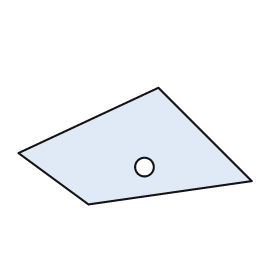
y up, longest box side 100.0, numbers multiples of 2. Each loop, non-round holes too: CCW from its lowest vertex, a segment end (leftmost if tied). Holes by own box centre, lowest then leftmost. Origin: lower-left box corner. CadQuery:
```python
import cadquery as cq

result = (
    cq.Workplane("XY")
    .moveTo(30.0, 0.0)
    .lineTo(100.0, 10.0)
    .lineTo(60.0, 50.0)
    .lineTo(0.0, 22.0)
    .close()
    .moveTo(54.0, 16.0)
    .circle(4.0)
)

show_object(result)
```